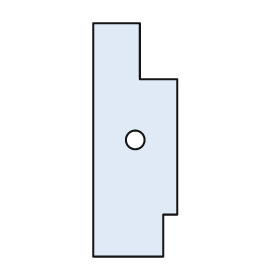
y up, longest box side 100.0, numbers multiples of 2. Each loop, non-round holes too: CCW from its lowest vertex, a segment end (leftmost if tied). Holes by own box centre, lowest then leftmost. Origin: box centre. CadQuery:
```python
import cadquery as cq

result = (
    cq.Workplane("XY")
    .moveTo(-18.0, -50.0)
    .lineTo(12.0, -50.0)
    .lineTo(12.0, -32.0)
    .lineTo(18.0, -32.0)
    .lineTo(18.0, 26.0)
    .lineTo(2.0, 26.0)
    .lineTo(2.0, 50.0)
    .lineTo(-18.0, 50.0)
    .close()
    .moveTo(0.0, 0.0)
    .circle(4.0)
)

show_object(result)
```